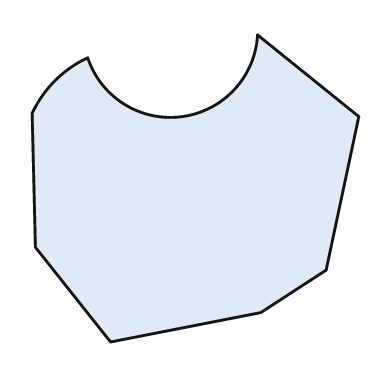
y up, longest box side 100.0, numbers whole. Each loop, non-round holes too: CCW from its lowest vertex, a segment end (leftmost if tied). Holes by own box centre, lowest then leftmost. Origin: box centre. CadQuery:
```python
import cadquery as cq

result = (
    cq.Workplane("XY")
    .moveTo(-26.0, -47.0)
    .lineTo(20.0, -38.0)
    .lineTo(40.0, -25.0)
    .lineTo(50.0, 22.0)
    .lineTo(19.0, 47.0)
    .threePointArc((-4.0, 22.0), (-33.0, 40.0))
    .threePointArc((-43.0, 33.0), (-50.0, 23.0))
    .lineTo(-49.0, -18.0)
    .close()
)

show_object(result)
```